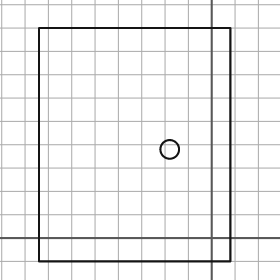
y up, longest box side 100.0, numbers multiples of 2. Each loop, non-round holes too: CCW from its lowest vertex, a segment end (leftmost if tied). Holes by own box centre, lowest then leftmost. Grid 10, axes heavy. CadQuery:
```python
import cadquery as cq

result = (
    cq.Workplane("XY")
    .moveTo(-74.0, -10.0)
    .lineTo(8.0, -10.0)
    .lineTo(8.0, 90.0)
    .lineTo(-74.0, 90.0)
    .close()
    .moveTo(-18.0, 38.0)
    .circle(4.0)
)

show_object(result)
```